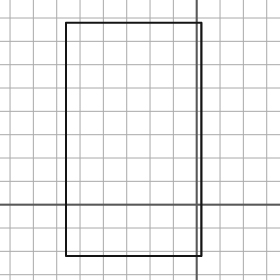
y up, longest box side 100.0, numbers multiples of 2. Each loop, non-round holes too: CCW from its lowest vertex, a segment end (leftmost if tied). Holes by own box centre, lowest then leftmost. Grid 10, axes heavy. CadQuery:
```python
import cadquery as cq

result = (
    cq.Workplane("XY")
    .moveTo(-56.0, -22.0)
    .lineTo(2.0, -22.0)
    .lineTo(2.0, 78.0)
    .lineTo(-56.0, 78.0)
    .close()
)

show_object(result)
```